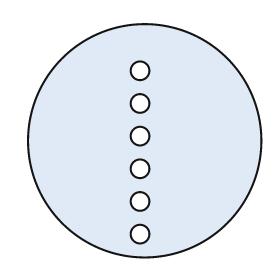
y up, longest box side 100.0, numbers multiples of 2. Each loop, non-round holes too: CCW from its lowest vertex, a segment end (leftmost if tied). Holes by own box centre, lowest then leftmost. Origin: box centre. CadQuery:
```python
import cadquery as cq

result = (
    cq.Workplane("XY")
    .moveTo(0.0, 0.0)
    .circle(50.0)
    .moveTo(-2.0, -40.0)
    .circle(4.0)
    .moveTo(-2.0, -26.0)
    .circle(4.0)
    .moveTo(-2.0, -12.0)
    .circle(4.0)
    .moveTo(-2.0, 2.0)
    .circle(4.0)
    .moveTo(-2.0, 16.0)
    .circle(4.0)
    .moveTo(-2.0, 30.0)
    .circle(4.0)
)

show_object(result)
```